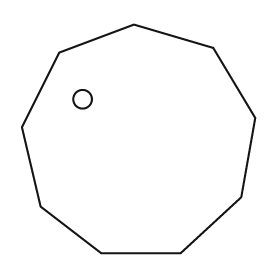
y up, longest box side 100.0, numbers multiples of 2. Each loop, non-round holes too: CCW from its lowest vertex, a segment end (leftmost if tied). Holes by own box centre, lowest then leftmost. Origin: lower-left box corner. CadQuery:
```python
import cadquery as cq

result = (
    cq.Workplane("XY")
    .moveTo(34.0, 0.0)
    .lineTo(68.0, 0.0)
    .lineTo(94.0, 24.0)
    .lineTo(100.0, 58.0)
    .lineTo(82.0, 88.0)
    .lineTo(48.0, 98.0)
    .lineTo(16.0, 86.0)
    .lineTo(0.0, 54.0)
    .lineTo(8.0, 20.0)
    .close()
    .moveTo(26.0, 66.0)
    .circle(4.0)
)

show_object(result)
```